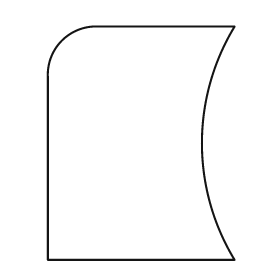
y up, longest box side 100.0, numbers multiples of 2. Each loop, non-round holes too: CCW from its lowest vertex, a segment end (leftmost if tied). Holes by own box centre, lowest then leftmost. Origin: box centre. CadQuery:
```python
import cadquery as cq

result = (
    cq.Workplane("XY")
    .moveTo(-40.0, -50.0)
    .lineTo(40.0, -50.0)
    .threePointArc((26.0, 0.0), (40.0, 50.0))
    .lineTo(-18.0, 50.0)
    .threePointArc((-34.0, 44.0), (-40.0, 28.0))
    .close()
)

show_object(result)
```